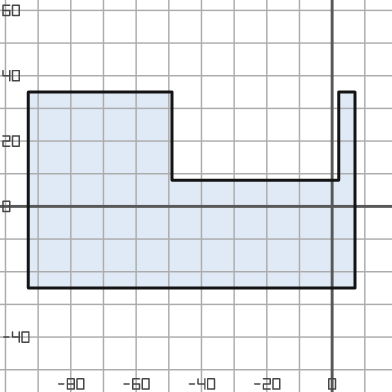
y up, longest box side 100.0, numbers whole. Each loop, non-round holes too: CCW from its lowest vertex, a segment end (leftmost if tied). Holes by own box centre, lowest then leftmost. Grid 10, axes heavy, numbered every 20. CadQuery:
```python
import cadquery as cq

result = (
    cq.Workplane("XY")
    .moveTo(-93.0, -25.0)
    .lineTo(7.0, -25.0)
    .lineTo(7.0, 35.0)
    .lineTo(2.0, 35.0)
    .lineTo(2.0, 8.0)
    .lineTo(-49.0, 8.0)
    .lineTo(-49.0, 35.0)
    .lineTo(-93.0, 35.0)
    .close()
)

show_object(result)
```